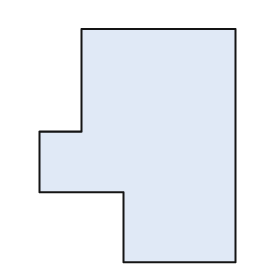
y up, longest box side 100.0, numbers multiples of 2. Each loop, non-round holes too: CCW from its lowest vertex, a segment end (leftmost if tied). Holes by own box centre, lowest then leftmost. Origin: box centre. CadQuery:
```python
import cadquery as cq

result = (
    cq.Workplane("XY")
    .moveTo(-6.0, -50.0)
    .lineTo(42.0, -50.0)
    .lineTo(42.0, 50.0)
    .lineTo(-24.0, 50.0)
    .lineTo(-24.0, 6.0)
    .lineTo(-42.0, 6.0)
    .lineTo(-42.0, -20.0)
    .lineTo(-6.0, -20.0)
    .close()
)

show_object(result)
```